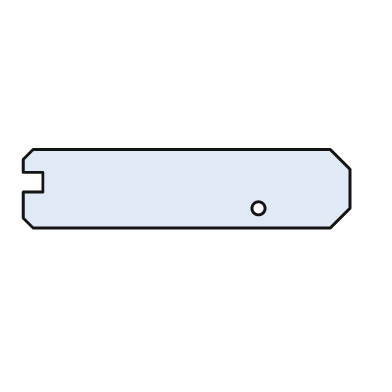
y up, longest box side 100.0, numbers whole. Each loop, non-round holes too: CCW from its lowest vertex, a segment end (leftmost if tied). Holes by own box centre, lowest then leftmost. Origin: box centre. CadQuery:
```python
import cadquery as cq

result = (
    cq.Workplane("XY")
    .moveTo(-47.0, -12.0)
    .lineTo(44.0, -12.0)
    .lineTo(50.0, -6.0)
    .lineTo(50.0, 6.0)
    .lineTo(44.0, 12.0)
    .lineTo(-47.0, 12.0)
    .lineTo(-50.0, 9.0)
    .lineTo(-50.0, 5.0)
    .lineTo(-44.0, 5.0)
    .lineTo(-44.0, -1.0)
    .lineTo(-50.0, -1.0)
    .lineTo(-50.0, -9.0)
    .close()
    .moveTo(22.0, -6.0)
    .circle(2.0)
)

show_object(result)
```